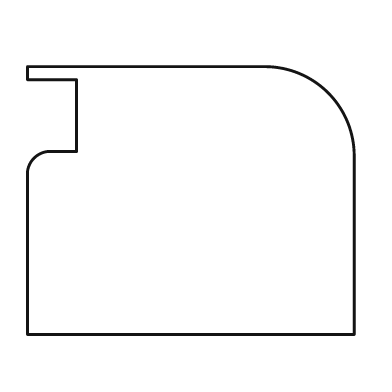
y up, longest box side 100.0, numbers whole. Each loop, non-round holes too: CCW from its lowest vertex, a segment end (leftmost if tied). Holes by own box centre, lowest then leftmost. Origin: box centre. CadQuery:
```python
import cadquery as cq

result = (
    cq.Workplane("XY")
    .moveTo(-50.0, -41.0)
    .lineTo(50.0, -41.0)
    .lineTo(50.0, 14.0)
    .threePointArc((42.0, 33.0), (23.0, 41.0))
    .lineTo(-50.0, 41.0)
    .lineTo(-50.0, 37.0)
    .lineTo(-35.0, 37.0)
    .lineTo(-35.0, 15.0)
    .lineTo(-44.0, 15.0)
    .threePointArc((-48.0, 13.0), (-50.0, 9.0))
    .close()
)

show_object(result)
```